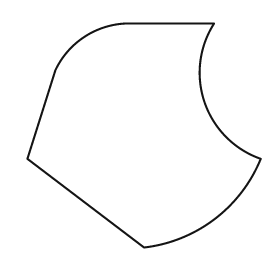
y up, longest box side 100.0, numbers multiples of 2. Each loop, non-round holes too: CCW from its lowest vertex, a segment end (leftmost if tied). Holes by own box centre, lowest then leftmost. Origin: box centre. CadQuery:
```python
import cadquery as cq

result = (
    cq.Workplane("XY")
    .moveTo(0.0, -48.0)
    .threePointArc((30.0, -36.0), (50.0, -10.0))
    .threePointArc((26.0, 14.0), (30.0, 48.0))
    .lineTo(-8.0, 48.0)
    .threePointArc((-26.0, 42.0), (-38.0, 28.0))
    .lineTo(-50.0, -10.0)
    .close()
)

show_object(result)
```